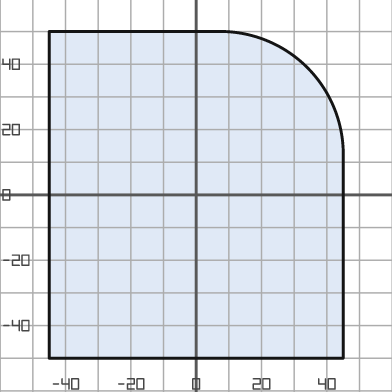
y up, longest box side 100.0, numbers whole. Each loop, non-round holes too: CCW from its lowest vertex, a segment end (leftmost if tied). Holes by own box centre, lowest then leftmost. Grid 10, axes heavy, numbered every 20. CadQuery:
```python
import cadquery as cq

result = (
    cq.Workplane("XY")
    .moveTo(-45.0, -50.0)
    .lineTo(45.0, -50.0)
    .lineTo(45.0, 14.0)
    .threePointArc((34.0, 39.0), (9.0, 50.0))
    .lineTo(-45.0, 50.0)
    .close()
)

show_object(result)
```